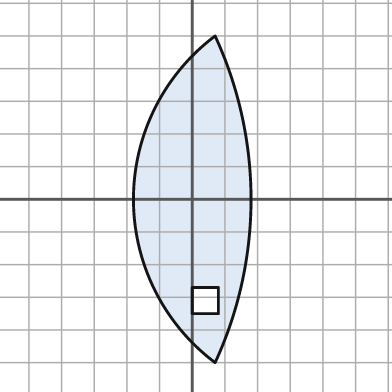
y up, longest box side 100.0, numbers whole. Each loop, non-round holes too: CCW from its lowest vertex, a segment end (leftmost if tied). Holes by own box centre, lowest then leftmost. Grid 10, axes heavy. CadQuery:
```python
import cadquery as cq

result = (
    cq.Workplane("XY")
    .moveTo(7.0, -50.0)
    .threePointArc((18.0, 0.0), (7.0, 50.0))
    .threePointArc((-18.0, 0.0), (7.0, -50.0))
    .close()
    .moveTo(0.0, -35.0)
    .lineTo(8.0, -35.0)
    .lineTo(8.0, -27.0)
    .lineTo(0.0, -27.0)
    .close()
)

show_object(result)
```